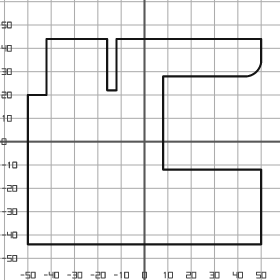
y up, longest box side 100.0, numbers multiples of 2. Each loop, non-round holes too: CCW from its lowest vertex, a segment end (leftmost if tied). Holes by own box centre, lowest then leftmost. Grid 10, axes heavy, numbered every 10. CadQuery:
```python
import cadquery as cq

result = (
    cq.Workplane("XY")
    .moveTo(-50.0, -44.0)
    .lineTo(50.0, -44.0)
    .lineTo(50.0, -12.0)
    .lineTo(8.0, -12.0)
    .lineTo(8.0, 28.0)
    .lineTo(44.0, 28.0)
    .threePointArc((48.0, 30.0), (50.0, 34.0))
    .lineTo(50.0, 44.0)
    .lineTo(-12.0, 44.0)
    .lineTo(-12.0, 22.0)
    .lineTo(-16.0, 22.0)
    .lineTo(-16.0, 44.0)
    .lineTo(-42.0, 44.0)
    .lineTo(-42.0, 20.0)
    .lineTo(-50.0, 20.0)
    .close()
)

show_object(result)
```